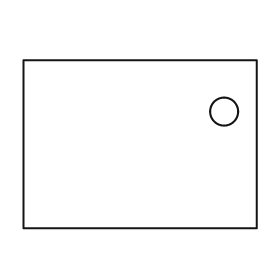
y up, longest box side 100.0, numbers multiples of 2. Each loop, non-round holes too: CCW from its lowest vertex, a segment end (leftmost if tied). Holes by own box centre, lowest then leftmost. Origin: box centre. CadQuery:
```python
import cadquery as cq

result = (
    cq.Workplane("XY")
    .moveTo(-50.0, -36.0)
    .lineTo(50.0, -36.0)
    .lineTo(50.0, 36.0)
    .lineTo(-50.0, 36.0)
    .close()
    .moveTo(36.0, 14.0)
    .circle(6.0)
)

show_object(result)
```